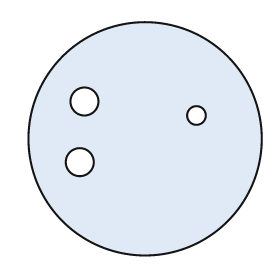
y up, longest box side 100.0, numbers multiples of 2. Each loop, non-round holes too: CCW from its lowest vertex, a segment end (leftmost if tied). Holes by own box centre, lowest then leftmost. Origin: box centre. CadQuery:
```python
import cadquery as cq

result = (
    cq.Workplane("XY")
    .moveTo(0.0, 0.0)
    .circle(50.0)
    .moveTo(-28.0, -10.0)
    .circle(6.0)
    .moveTo(22.0, 10.0)
    .circle(4.0)
    .moveTo(-26.0, 16.0)
    .circle(6.0)
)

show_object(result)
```